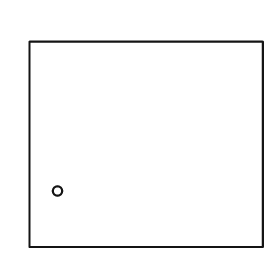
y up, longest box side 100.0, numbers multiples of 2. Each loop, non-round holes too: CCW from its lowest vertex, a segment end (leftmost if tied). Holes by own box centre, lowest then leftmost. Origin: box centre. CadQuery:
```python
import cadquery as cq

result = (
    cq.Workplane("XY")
    .moveTo(-50.0, -44.0)
    .lineTo(50.0, -44.0)
    .lineTo(50.0, 44.0)
    .lineTo(-50.0, 44.0)
    .close()
    .moveTo(-38.0, -20.0)
    .circle(2.0)
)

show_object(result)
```